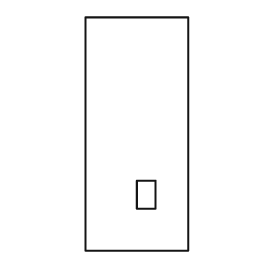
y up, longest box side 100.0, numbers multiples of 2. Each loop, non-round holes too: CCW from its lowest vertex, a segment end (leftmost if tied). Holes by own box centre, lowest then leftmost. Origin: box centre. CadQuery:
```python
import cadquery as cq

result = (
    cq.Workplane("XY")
    .moveTo(-22.0, -50.0)
    .lineTo(22.0, -50.0)
    .lineTo(22.0, 50.0)
    .lineTo(-22.0, 50.0)
    .close()
    .moveTo(0.0, -32.0)
    .lineTo(8.0, -32.0)
    .lineTo(8.0, -20.0)
    .lineTo(0.0, -20.0)
    .close()
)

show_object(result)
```